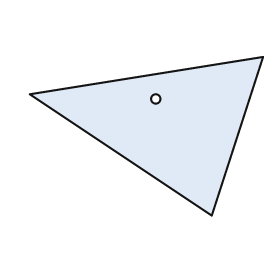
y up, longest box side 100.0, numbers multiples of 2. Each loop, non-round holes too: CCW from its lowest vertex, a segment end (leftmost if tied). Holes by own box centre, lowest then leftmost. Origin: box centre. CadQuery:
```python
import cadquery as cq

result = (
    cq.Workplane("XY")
    .moveTo(28.0, -34.0)
    .lineTo(50.0, 34.0)
    .lineTo(-50.0, 18.0)
    .close()
    .moveTo(4.0, 16.0)
    .circle(2.0)
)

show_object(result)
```